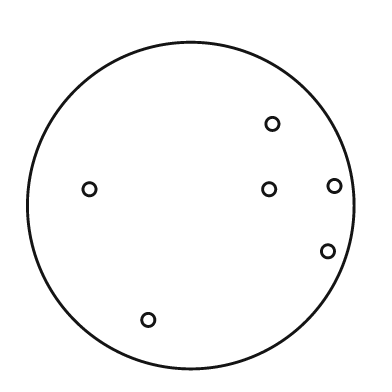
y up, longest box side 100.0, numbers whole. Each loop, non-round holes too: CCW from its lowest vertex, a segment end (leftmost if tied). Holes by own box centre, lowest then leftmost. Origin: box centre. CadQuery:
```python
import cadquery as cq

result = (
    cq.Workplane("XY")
    .moveTo(0.0, 0.0)
    .circle(50.0)
    .moveTo(-13.0, -35.0)
    .circle(2.0)
    .moveTo(42.0, -14.0)
    .circle(2.0)
    .moveTo(-31.0, 5.0)
    .circle(2.0)
    .moveTo(24.0, 5.0)
    .circle(2.0)
    .moveTo(44.0, 6.0)
    .circle(2.0)
    .moveTo(25.0, 25.0)
    .circle(2.0)
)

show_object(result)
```